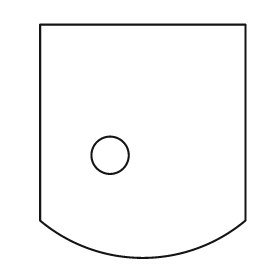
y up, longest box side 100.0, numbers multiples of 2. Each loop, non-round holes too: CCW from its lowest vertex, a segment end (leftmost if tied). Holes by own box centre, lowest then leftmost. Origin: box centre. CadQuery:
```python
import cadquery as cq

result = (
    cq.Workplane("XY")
    .moveTo(-44.0, -34.0)
    .threePointArc((0.0, -50.0), (44.0, -34.0))
    .lineTo(44.0, 50.0)
    .lineTo(-44.0, 50.0)
    .close()
    .moveTo(-14.0, -6.0)
    .circle(8.0)
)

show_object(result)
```